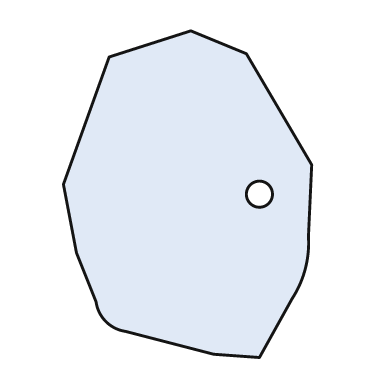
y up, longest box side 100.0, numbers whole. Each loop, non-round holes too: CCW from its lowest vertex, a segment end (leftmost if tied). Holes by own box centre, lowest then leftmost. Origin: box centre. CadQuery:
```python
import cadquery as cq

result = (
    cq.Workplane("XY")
    .moveTo(22.0, -50.0)
    .lineTo(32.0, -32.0)
    .threePointArc((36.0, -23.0), (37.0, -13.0))
    .lineTo(38.0, 9.0)
    .lineTo(18.0, 43.0)
    .lineTo(1.0, 50.0)
    .lineTo(-24.0, 42.0)
    .lineTo(-38.0, 3.0)
    .lineTo(-34.0, -18.0)
    .lineTo(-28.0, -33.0)
    .threePointArc((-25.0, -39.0), (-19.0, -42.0))
    .lineTo(8.0, -49.0)
    .close()
    .moveTo(22.0, 0.0)
    .circle(4.0)
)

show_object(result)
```